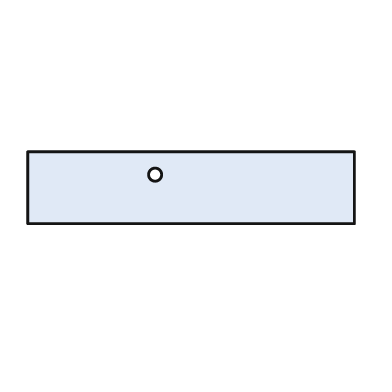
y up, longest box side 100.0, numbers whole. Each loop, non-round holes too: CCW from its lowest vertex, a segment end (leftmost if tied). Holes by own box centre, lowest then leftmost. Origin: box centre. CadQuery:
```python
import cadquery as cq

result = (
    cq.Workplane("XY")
    .moveTo(-50.0, -11.0)
    .lineTo(50.0, -11.0)
    .lineTo(50.0, 11.0)
    .lineTo(-50.0, 11.0)
    .close()
    .moveTo(-11.0, 4.0)
    .circle(2.0)
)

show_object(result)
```